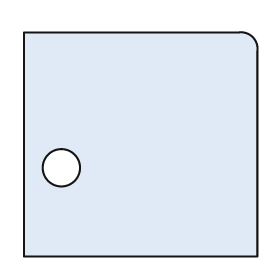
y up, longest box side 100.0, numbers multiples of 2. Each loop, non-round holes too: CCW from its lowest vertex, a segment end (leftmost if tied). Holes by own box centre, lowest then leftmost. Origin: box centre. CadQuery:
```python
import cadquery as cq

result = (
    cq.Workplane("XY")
    .moveTo(-50.0, -48.0)
    .lineTo(50.0, -48.0)
    .lineTo(50.0, 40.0)
    .threePointArc((48.0, 46.0), (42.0, 48.0))
    .lineTo(-50.0, 48.0)
    .close()
    .moveTo(-34.0, -10.0)
    .circle(8.0)
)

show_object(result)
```